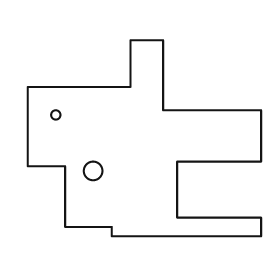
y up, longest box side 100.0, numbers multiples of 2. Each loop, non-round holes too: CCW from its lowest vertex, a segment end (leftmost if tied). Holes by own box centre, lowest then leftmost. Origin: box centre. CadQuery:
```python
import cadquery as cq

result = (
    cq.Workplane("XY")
    .moveTo(-14.0, -42.0)
    .lineTo(50.0, -42.0)
    .lineTo(50.0, -34.0)
    .lineTo(14.0, -34.0)
    .lineTo(14.0, -10.0)
    .lineTo(50.0, -10.0)
    .lineTo(50.0, 12.0)
    .lineTo(8.0, 12.0)
    .lineTo(8.0, 42.0)
    .lineTo(-6.0, 42.0)
    .lineTo(-6.0, 22.0)
    .lineTo(-50.0, 22.0)
    .lineTo(-50.0, -12.0)
    .lineTo(-34.0, -12.0)
    .lineTo(-34.0, -38.0)
    .lineTo(-14.0, -38.0)
    .close()
    .moveTo(-22.0, -14.0)
    .circle(4.0)
    .moveTo(-38.0, 10.0)
    .circle(2.0)
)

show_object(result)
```